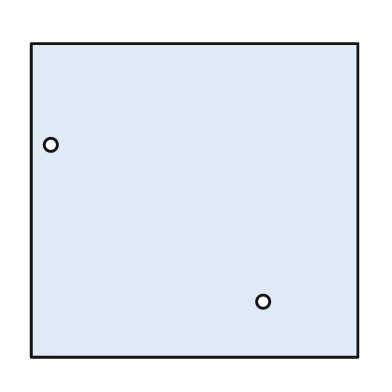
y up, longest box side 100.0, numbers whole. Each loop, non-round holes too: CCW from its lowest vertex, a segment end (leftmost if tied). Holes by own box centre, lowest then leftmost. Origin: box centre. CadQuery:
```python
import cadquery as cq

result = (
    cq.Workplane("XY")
    .moveTo(-50.0, -48.0)
    .lineTo(50.0, -48.0)
    .lineTo(50.0, 48.0)
    .lineTo(-50.0, 48.0)
    .close()
    .moveTo(21.0, -31.0)
    .circle(2.0)
    .moveTo(-44.0, 17.0)
    .circle(2.0)
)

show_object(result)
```